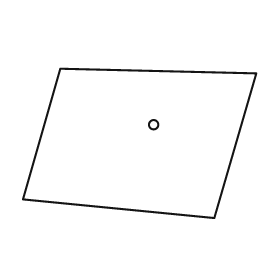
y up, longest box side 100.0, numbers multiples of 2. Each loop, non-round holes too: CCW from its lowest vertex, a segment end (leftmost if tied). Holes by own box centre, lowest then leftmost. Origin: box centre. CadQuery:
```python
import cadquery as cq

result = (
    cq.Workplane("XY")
    .moveTo(32.0, -32.0)
    .lineTo(50.0, 30.0)
    .lineTo(-34.0, 32.0)
    .lineTo(-50.0, -24.0)
    .close()
    .moveTo(6.0, 8.0)
    .circle(2.0)
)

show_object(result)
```